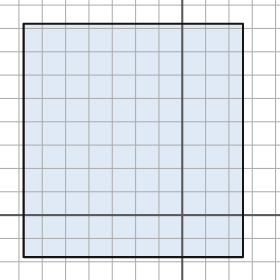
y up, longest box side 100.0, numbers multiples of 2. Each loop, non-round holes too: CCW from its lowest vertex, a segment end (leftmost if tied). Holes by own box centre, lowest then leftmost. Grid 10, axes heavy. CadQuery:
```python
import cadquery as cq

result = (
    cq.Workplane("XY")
    .moveTo(-68.0, -18.0)
    .lineTo(26.0, -18.0)
    .lineTo(26.0, 82.0)
    .lineTo(-68.0, 82.0)
    .close()
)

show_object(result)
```